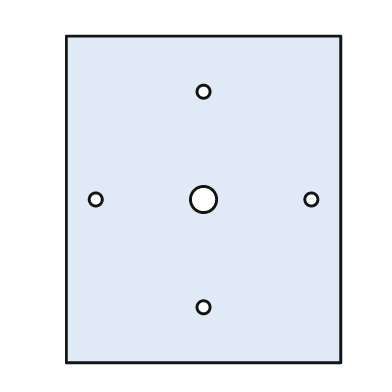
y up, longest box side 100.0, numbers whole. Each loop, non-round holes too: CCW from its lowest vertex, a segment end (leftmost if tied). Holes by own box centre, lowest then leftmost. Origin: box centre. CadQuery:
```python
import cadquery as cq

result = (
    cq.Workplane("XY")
    .moveTo(-42.0, -50.0)
    .lineTo(42.0, -50.0)
    .lineTo(42.0, 50.0)
    .lineTo(-42.0, 50.0)
    .close()
    .moveTo(0.0, -33.0)
    .circle(2.0)
    .moveTo(-33.0, 0.0)
    .circle(2.0)
    .moveTo(0.0, 0.0)
    .circle(4.0)
    .moveTo(33.0, 0.0)
    .circle(2.0)
    .moveTo(0.0, 33.0)
    .circle(2.0)
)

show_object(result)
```